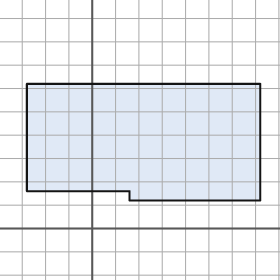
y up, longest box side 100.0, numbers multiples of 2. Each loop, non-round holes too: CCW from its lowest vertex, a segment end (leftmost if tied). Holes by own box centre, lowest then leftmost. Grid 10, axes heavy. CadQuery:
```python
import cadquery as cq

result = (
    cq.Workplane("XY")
    .moveTo(16.0, 12.0)
    .lineTo(72.0, 12.0)
    .lineTo(72.0, 62.0)
    .lineTo(-28.0, 62.0)
    .lineTo(-28.0, 16.0)
    .lineTo(16.0, 16.0)
    .close()
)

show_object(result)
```